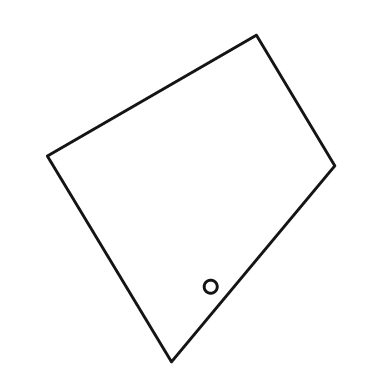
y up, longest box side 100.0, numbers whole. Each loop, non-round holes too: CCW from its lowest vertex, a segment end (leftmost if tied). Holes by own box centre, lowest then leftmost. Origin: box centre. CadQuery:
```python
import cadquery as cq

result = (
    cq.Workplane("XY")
    .moveTo(-6.0, -50.0)
    .lineTo(44.0, 10.0)
    .lineTo(20.0, 50.0)
    .lineTo(-44.0, 13.0)
    .close()
    .moveTo(6.0, -27.0)
    .circle(2.0)
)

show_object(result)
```